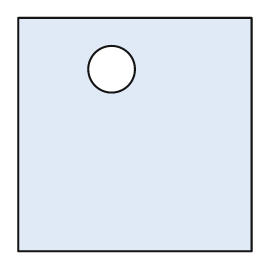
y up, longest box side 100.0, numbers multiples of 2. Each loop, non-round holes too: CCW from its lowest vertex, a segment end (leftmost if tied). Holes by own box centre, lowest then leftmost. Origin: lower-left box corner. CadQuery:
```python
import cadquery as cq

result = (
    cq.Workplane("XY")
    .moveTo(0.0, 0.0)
    .lineTo(100.0, 0.0)
    .lineTo(100.0, 100.0)
    .lineTo(0.0, 100.0)
    .close()
    .moveTo(40.0, 78.0)
    .circle(10.0)
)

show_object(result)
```